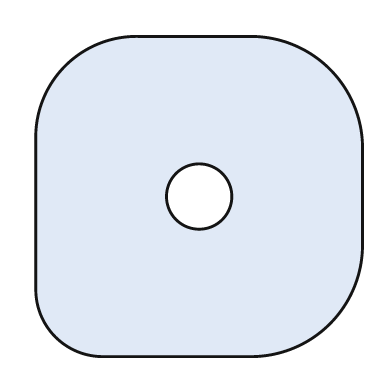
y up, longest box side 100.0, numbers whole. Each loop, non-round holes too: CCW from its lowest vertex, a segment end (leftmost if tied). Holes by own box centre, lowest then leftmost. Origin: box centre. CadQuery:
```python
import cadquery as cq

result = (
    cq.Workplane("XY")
    .moveTo(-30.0, -49.0)
    .lineTo(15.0, -49.0)
    .threePointArc((40.0, -39.0), (50.0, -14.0))
    .lineTo(50.0, 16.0)
    .threePointArc((40.0, 39.0), (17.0, 49.0))
    .lineTo(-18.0, 49.0)
    .threePointArc((-41.0, 40.0), (-50.0, 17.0))
    .lineTo(-50.0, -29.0)
    .threePointArc((-44.0, -43.0), (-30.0, -49.0))
    .close()
    .moveTo(0.0, 0.0)
    .circle(10.0)
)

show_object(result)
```